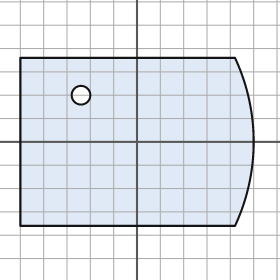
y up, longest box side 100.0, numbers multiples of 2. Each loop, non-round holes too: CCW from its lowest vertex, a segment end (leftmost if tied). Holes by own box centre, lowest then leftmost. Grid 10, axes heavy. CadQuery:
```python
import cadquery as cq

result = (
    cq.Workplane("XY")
    .moveTo(-50.0, -36.0)
    .lineTo(42.0, -36.0)
    .threePointArc((50.0, 0.0), (42.0, 36.0))
    .lineTo(-50.0, 36.0)
    .close()
    .moveTo(-24.0, 20.0)
    .circle(4.0)
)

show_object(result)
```